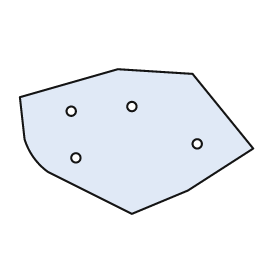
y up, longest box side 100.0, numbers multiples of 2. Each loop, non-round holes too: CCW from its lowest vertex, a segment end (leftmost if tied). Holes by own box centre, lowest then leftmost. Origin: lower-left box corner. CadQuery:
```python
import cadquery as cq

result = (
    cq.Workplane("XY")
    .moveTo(48.0, 0.0)
    .lineTo(72.0, 10.0)
    .lineTo(100.0, 28.0)
    .lineTo(74.0, 60.0)
    .lineTo(42.0, 62.0)
    .lineTo(0.0, 50.0)
    .lineTo(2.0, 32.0)
    .threePointArc((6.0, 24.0), (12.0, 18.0))
    .close()
    .moveTo(24.0, 24.0)
    .circle(2.0)
    .moveTo(76.0, 30.0)
    .circle(2.0)
    .moveTo(22.0, 44.0)
    .circle(2.0)
    .moveTo(48.0, 46.0)
    .circle(2.0)
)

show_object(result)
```